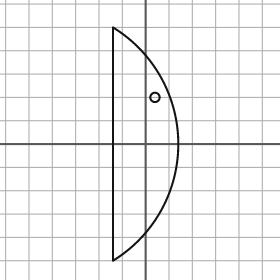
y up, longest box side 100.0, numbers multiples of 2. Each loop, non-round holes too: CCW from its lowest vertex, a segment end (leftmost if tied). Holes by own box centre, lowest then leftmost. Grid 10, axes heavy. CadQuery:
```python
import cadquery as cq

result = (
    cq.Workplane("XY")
    .moveTo(-14.0, -50.0)
    .threePointArc((14.0, 0.0), (-14.0, 50.0))
    .close()
    .moveTo(4.0, 20.0)
    .circle(2.0)
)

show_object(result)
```